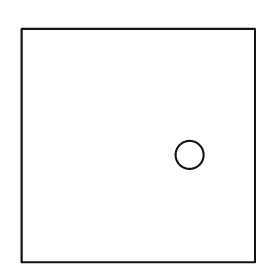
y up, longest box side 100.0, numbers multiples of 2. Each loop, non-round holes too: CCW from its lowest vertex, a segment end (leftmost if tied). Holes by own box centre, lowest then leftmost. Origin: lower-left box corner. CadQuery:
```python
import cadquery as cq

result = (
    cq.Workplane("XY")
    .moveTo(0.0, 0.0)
    .lineTo(100.0, 0.0)
    .lineTo(100.0, 100.0)
    .lineTo(0.0, 100.0)
    .close()
    .moveTo(72.0, 46.0)
    .circle(6.0)
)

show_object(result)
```